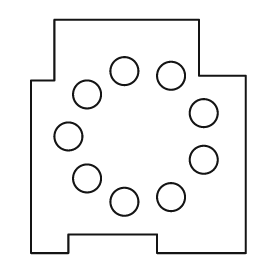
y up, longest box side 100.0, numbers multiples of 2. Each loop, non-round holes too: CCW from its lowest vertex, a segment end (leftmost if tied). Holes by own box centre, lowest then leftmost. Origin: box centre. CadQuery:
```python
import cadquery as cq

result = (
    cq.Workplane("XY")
    .moveTo(-46.0, -50.0)
    .lineTo(-30.0, -50.0)
    .lineTo(-30.0, -42.0)
    .lineTo(8.0, -42.0)
    .lineTo(8.0, -50.0)
    .lineTo(46.0, -50.0)
    .lineTo(46.0, 26.0)
    .lineTo(26.0, 26.0)
    .lineTo(26.0, 50.0)
    .lineTo(-36.0, 50.0)
    .lineTo(-36.0, 24.0)
    .lineTo(-46.0, 24.0)
    .close()
    .moveTo(-6.0, -28.0)
    .circle(6.0)
    .moveTo(14.0, -26.0)
    .circle(6.0)
    .moveTo(-22.0, -18.0)
    .circle(6.0)
    .moveTo(28.0, -10.0)
    .circle(6.0)
    .moveTo(-30.0, 0.0)
    .circle(6.0)
    .moveTo(28.0, 10.0)
    .circle(6.0)
    .moveTo(-22.0, 18.0)
    .circle(6.0)
    .moveTo(14.0, 26.0)
    .circle(6.0)
    .moveTo(-6.0, 28.0)
    .circle(6.0)
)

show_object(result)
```